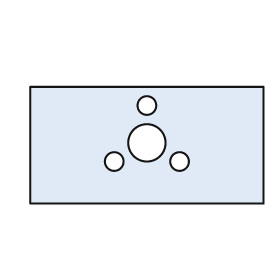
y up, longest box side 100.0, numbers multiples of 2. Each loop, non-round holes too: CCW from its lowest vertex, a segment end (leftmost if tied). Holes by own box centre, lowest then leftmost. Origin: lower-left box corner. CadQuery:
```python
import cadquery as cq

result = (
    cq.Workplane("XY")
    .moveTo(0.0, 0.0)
    .lineTo(100.0, 0.0)
    .lineTo(100.0, 50.0)
    .lineTo(0.0, 50.0)
    .close()
    .moveTo(36.0, 18.0)
    .circle(4.0)
    .moveTo(64.0, 18.0)
    .circle(4.0)
    .moveTo(50.0, 26.0)
    .circle(8.0)
    .moveTo(50.0, 42.0)
    .circle(4.0)
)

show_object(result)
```